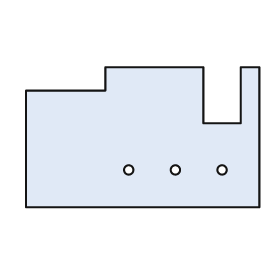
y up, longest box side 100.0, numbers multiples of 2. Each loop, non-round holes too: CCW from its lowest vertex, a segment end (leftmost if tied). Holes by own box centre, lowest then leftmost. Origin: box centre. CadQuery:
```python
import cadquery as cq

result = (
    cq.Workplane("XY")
    .moveTo(-50.0, -30.0)
    .lineTo(50.0, -30.0)
    .lineTo(50.0, 30.0)
    .lineTo(42.0, 30.0)
    .lineTo(42.0, 6.0)
    .lineTo(26.0, 6.0)
    .lineTo(26.0, 30.0)
    .lineTo(-16.0, 30.0)
    .lineTo(-16.0, 20.0)
    .lineTo(-50.0, 20.0)
    .close()
    .moveTo(-6.0, -14.0)
    .circle(2.0)
    .moveTo(14.0, -14.0)
    .circle(2.0)
    .moveTo(34.0, -14.0)
    .circle(2.0)
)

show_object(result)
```